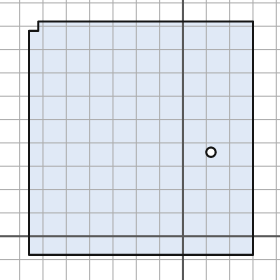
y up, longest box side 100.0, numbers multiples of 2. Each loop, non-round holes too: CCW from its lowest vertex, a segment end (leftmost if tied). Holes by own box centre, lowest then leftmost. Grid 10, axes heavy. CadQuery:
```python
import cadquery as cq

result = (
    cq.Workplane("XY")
    .moveTo(-66.0, -8.0)
    .lineTo(30.0, -8.0)
    .lineTo(30.0, 92.0)
    .lineTo(-62.0, 92.0)
    .lineTo(-62.0, 88.0)
    .lineTo(-66.0, 88.0)
    .close()
    .moveTo(12.0, 36.0)
    .circle(2.0)
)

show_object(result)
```